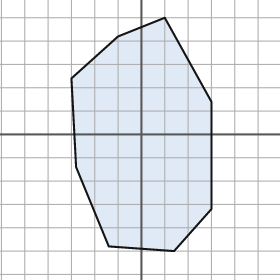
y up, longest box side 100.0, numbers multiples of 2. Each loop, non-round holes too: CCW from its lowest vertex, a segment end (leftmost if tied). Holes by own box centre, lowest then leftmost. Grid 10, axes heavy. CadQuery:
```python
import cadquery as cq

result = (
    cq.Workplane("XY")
    .moveTo(14.0, -50.0)
    .lineTo(30.0, -32.0)
    .lineTo(30.0, 14.0)
    .lineTo(10.0, 50.0)
    .lineTo(-10.0, 42.0)
    .lineTo(-30.0, 24.0)
    .lineTo(-28.0, -14.0)
    .lineTo(-14.0, -48.0)
    .close()
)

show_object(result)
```